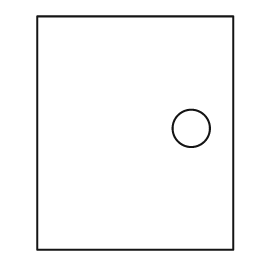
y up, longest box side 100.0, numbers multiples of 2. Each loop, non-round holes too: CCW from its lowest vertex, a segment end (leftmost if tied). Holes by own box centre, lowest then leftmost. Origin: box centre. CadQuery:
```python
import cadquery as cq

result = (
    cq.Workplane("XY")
    .moveTo(-42.0, -50.0)
    .lineTo(42.0, -50.0)
    .lineTo(42.0, 50.0)
    .lineTo(-42.0, 50.0)
    .close()
    .moveTo(24.0, 2.0)
    .circle(8.0)
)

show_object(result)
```